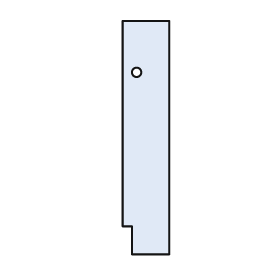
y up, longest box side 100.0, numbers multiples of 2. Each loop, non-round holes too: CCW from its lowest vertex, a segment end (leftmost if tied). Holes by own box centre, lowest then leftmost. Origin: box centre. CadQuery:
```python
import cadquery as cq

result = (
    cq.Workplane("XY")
    .moveTo(-6.0, -50.0)
    .lineTo(10.0, -50.0)
    .lineTo(10.0, 50.0)
    .lineTo(-10.0, 50.0)
    .lineTo(-10.0, -38.0)
    .lineTo(-6.0, -38.0)
    .close()
    .moveTo(-4.0, 28.0)
    .circle(2.0)
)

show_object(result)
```